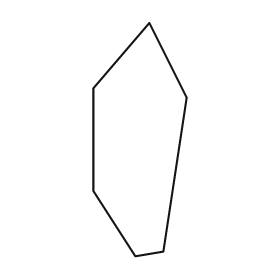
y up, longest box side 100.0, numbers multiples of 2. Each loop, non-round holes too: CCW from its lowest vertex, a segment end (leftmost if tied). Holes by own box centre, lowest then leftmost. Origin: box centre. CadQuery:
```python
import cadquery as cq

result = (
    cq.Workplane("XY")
    .moveTo(-2.0, -50.0)
    .lineTo(10.0, -48.0)
    .lineTo(20.0, 18.0)
    .lineTo(4.0, 50.0)
    .lineTo(-20.0, 22.0)
    .lineTo(-20.0, -22.0)
    .close()
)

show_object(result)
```